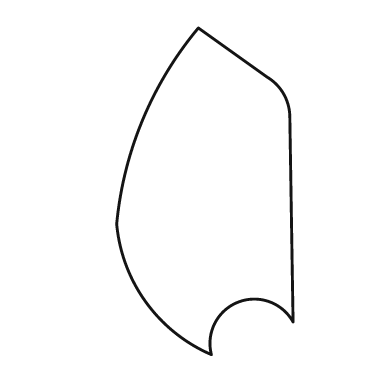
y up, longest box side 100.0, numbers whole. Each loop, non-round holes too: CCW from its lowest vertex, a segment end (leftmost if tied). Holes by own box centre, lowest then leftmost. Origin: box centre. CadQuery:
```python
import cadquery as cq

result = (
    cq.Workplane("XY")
    .moveTo(2.0, -50.0)
    .threePointArc((10.0, -34.0), (27.0, -40.0))
    .lineTo(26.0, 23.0)
    .threePointArc((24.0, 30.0), (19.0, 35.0))
    .lineTo(-2.0, 50.0)
    .threePointArc((-19.0, 22.0), (-27.0, -10.0))
    .threePointArc((-18.0, -34.0), (2.0, -50.0))
    .close()
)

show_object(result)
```